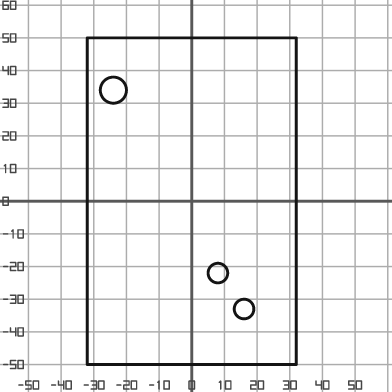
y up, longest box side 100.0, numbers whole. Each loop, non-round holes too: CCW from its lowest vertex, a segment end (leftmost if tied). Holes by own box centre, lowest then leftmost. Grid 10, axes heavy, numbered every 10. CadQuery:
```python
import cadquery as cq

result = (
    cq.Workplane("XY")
    .moveTo(-32.0, -50.0)
    .lineTo(32.0, -50.0)
    .lineTo(32.0, 50.0)
    .lineTo(-32.0, 50.0)
    .close()
    .moveTo(16.0, -33.0)
    .circle(3.0)
    .moveTo(8.0, -22.0)
    .circle(3.0)
    .moveTo(-24.0, 34.0)
    .circle(4.0)
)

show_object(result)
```